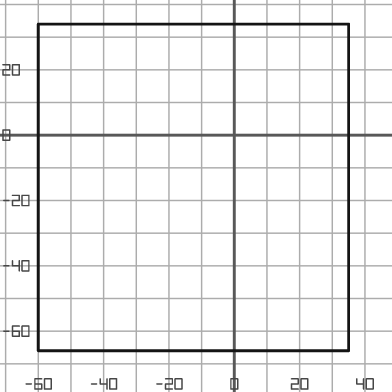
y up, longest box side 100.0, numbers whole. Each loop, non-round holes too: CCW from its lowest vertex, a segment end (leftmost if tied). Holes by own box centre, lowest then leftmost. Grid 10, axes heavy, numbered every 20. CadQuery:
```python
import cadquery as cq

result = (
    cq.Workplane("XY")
    .moveTo(-60.0, -66.0)
    .lineTo(35.0, -66.0)
    .lineTo(35.0, 34.0)
    .lineTo(-60.0, 34.0)
    .close()
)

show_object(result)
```